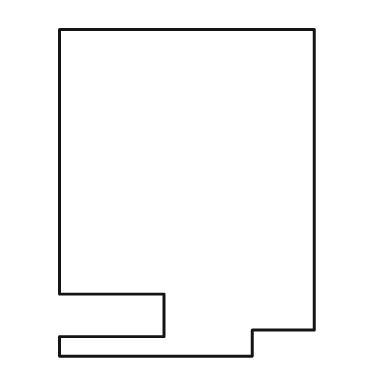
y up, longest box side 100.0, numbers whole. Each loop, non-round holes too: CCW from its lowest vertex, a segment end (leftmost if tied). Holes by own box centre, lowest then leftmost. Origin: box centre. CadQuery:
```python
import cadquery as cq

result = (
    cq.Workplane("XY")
    .moveTo(-39.0, -50.0)
    .lineTo(20.0, -50.0)
    .lineTo(20.0, -42.0)
    .lineTo(39.0, -42.0)
    .lineTo(39.0, 50.0)
    .lineTo(-39.0, 50.0)
    .lineTo(-39.0, -31.0)
    .lineTo(-7.0, -31.0)
    .lineTo(-7.0, -44.0)
    .lineTo(-39.0, -44.0)
    .close()
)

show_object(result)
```